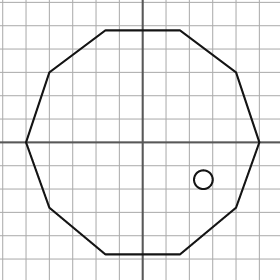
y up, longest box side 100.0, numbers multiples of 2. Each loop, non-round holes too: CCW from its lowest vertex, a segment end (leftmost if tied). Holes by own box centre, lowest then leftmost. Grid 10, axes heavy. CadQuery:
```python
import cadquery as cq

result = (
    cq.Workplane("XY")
    .moveTo(-16.0, -48.0)
    .lineTo(16.0, -48.0)
    .lineTo(40.0, -28.0)
    .lineTo(50.0, 0.0)
    .lineTo(40.0, 30.0)
    .lineTo(16.0, 48.0)
    .lineTo(-16.0, 48.0)
    .lineTo(-40.0, 30.0)
    .lineTo(-50.0, 0.0)
    .lineTo(-40.0, -28.0)
    .close()
    .moveTo(26.0, -16.0)
    .circle(4.0)
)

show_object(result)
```